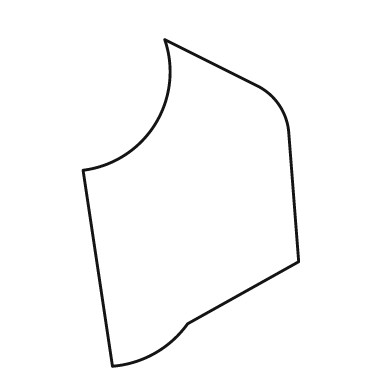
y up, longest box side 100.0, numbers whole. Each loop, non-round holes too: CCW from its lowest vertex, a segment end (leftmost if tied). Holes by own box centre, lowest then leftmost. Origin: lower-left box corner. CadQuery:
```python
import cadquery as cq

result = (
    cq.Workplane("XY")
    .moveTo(9.0, 0.0)
    .threePointArc((22.0, 4.0), (32.0, 13.0))
    .lineTo(66.0, 32.0)
    .lineTo(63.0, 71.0)
    .threePointArc((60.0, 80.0), (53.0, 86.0))
    .lineTo(25.0, 100.0)
    .threePointArc((22.0, 74.0), (0.0, 60.0))
    .close()
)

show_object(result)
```